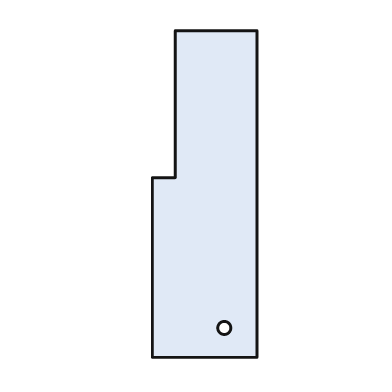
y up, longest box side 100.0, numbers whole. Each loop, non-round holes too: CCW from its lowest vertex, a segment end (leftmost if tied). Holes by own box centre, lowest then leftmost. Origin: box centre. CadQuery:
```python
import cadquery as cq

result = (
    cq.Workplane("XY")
    .moveTo(-16.0, -50.0)
    .lineTo(16.0, -50.0)
    .lineTo(16.0, 50.0)
    .lineTo(-9.0, 50.0)
    .lineTo(-9.0, 5.0)
    .lineTo(-16.0, 5.0)
    .close()
    .moveTo(6.0, -41.0)
    .circle(2.0)
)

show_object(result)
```